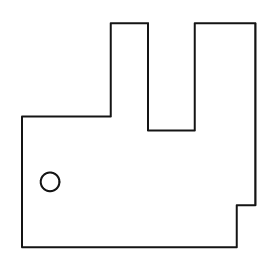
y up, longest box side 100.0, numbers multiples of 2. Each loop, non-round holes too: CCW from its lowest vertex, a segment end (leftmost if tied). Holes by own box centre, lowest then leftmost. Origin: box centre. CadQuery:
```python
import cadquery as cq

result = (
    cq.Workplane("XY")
    .moveTo(-50.0, -48.0)
    .lineTo(42.0, -48.0)
    .lineTo(42.0, -30.0)
    .lineTo(50.0, -30.0)
    .lineTo(50.0, 48.0)
    .lineTo(24.0, 48.0)
    .lineTo(24.0, 2.0)
    .lineTo(4.0, 2.0)
    .lineTo(4.0, 48.0)
    .lineTo(-12.0, 48.0)
    .lineTo(-12.0, 8.0)
    .lineTo(-50.0, 8.0)
    .close()
    .moveTo(-38.0, -20.0)
    .circle(4.0)
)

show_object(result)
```